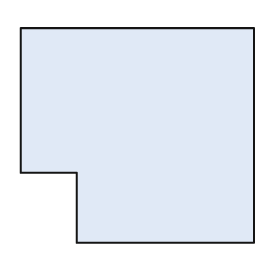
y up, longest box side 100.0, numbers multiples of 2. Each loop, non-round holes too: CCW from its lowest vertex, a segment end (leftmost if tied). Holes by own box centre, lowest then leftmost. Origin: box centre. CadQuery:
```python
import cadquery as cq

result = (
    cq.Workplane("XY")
    .moveTo(-26.0, -46.0)
    .lineTo(50.0, -46.0)
    .lineTo(50.0, 46.0)
    .lineTo(-50.0, 46.0)
    .lineTo(-50.0, -16.0)
    .lineTo(-26.0, -16.0)
    .close()
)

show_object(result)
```